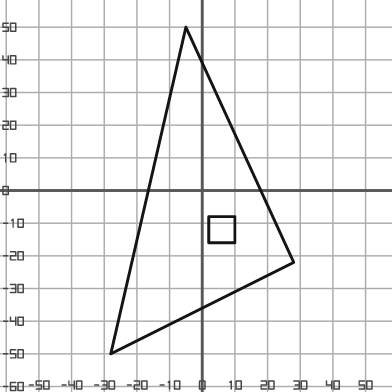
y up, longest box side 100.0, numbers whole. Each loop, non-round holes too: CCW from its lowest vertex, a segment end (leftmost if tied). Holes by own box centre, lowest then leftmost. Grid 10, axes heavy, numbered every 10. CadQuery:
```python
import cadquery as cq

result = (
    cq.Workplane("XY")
    .moveTo(-28.0, -50.0)
    .lineTo(28.0, -22.0)
    .lineTo(-5.0, 50.0)
    .close()
    .moveTo(2.0, -16.0)
    .lineTo(10.0, -16.0)
    .lineTo(10.0, -8.0)
    .lineTo(2.0, -8.0)
    .close()
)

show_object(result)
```